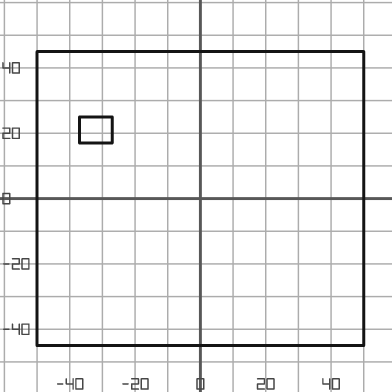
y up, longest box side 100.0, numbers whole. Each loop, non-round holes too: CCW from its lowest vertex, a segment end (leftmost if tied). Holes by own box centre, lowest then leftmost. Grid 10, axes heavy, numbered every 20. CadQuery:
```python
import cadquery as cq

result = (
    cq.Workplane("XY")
    .moveTo(-50.0, -45.0)
    .lineTo(50.0, -45.0)
    .lineTo(50.0, 45.0)
    .lineTo(-50.0, 45.0)
    .close()
    .moveTo(-37.0, 17.0)
    .lineTo(-27.0, 17.0)
    .lineTo(-27.0, 25.0)
    .lineTo(-37.0, 25.0)
    .close()
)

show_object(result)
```